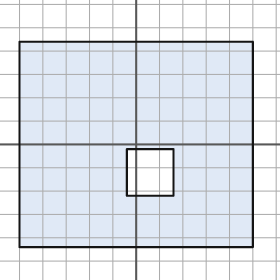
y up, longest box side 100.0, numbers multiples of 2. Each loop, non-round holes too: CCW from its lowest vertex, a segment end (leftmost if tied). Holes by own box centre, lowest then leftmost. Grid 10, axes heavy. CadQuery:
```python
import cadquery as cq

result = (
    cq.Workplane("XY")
    .moveTo(-50.0, -44.0)
    .lineTo(50.0, -44.0)
    .lineTo(50.0, 44.0)
    .lineTo(-50.0, 44.0)
    .close()
    .moveTo(-4.0, -22.0)
    .lineTo(16.0, -22.0)
    .lineTo(16.0, -2.0)
    .lineTo(-4.0, -2.0)
    .close()
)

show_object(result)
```